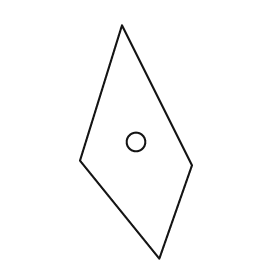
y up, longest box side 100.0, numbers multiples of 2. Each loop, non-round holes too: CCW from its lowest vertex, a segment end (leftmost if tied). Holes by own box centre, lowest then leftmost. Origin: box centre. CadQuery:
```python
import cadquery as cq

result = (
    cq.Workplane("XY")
    .moveTo(10.0, -50.0)
    .lineTo(24.0, -10.0)
    .lineTo(-6.0, 50.0)
    .lineTo(-24.0, -8.0)
    .close()
    .moveTo(0.0, 0.0)
    .circle(4.0)
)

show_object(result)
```